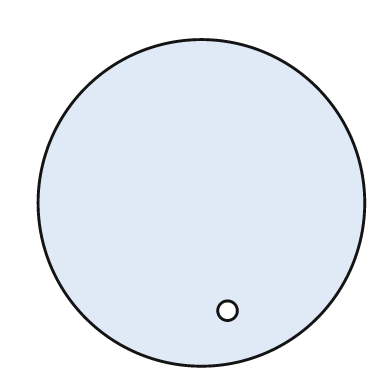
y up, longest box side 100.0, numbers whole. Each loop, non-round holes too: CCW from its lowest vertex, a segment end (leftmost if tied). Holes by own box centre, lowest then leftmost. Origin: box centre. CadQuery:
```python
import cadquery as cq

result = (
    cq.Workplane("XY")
    .moveTo(0.0, 0.0)
    .circle(50.0)
    .moveTo(8.0, -33.0)
    .circle(3.0)
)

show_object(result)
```